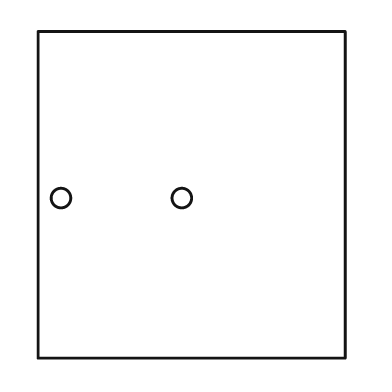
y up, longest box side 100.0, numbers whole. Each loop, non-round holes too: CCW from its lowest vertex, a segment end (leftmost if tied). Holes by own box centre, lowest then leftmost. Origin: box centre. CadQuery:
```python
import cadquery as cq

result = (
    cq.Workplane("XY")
    .moveTo(-47.0, -50.0)
    .lineTo(47.0, -50.0)
    .lineTo(47.0, 50.0)
    .lineTo(-47.0, 50.0)
    .close()
    .moveTo(-40.0, -1.0)
    .circle(3.0)
    .moveTo(-3.0, -1.0)
    .circle(3.0)
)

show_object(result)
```